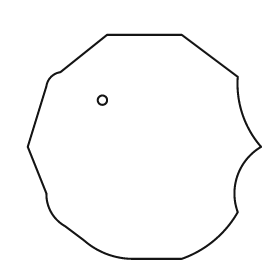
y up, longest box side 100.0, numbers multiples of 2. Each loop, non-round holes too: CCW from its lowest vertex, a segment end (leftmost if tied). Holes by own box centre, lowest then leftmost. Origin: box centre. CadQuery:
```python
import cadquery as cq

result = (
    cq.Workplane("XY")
    .moveTo(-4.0, -48.0)
    .lineTo(16.0, -48.0)
    .threePointArc((30.0, -40.0), (40.0, -28.0))
    .threePointArc((40.0, -12.0), (50.0, 0.0))
    .threePointArc((42.0, 14.0), (40.0, 30.0))
    .lineTo(16.0, 48.0)
    .lineTo(-16.0, 48.0)
    .lineTo(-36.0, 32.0)
    .threePointArc((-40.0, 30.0), (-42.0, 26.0))
    .lineTo(-50.0, 0.0)
    .lineTo(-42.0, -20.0)
    .threePointArc((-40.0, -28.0), (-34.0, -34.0))
    .lineTo(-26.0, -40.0)
    .threePointArc((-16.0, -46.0), (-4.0, -48.0))
    .close()
    .moveTo(-18.0, 20.0)
    .circle(2.0)
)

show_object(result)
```